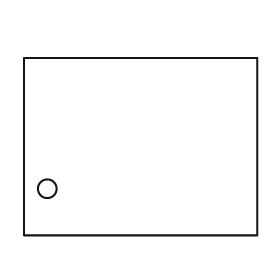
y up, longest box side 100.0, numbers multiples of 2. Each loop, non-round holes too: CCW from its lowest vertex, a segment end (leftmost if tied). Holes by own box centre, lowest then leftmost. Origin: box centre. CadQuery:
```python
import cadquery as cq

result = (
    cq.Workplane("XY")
    .moveTo(-50.0, -38.0)
    .lineTo(50.0, -38.0)
    .lineTo(50.0, 38.0)
    .lineTo(-50.0, 38.0)
    .close()
    .moveTo(-40.0, -18.0)
    .circle(4.0)
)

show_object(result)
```